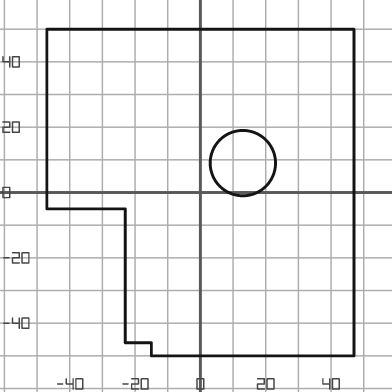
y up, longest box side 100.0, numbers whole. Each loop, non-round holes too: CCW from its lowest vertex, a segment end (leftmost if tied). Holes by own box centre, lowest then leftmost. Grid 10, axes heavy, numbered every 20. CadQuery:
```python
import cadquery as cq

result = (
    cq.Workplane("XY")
    .moveTo(-15.0, -50.0)
    .lineTo(47.0, -50.0)
    .lineTo(47.0, 50.0)
    .lineTo(-47.0, 50.0)
    .lineTo(-47.0, -5.0)
    .lineTo(-23.0, -5.0)
    .lineTo(-23.0, -46.0)
    .lineTo(-15.0, -46.0)
    .close()
    .moveTo(13.0, 9.0)
    .circle(10.0)
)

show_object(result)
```